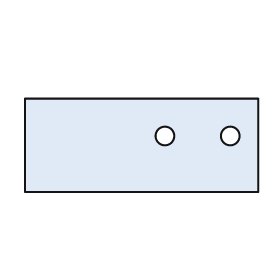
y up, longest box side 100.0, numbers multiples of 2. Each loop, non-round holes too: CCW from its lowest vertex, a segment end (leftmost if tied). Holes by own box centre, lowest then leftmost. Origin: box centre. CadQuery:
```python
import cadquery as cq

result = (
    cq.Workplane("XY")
    .moveTo(-50.0, -20.0)
    .lineTo(50.0, -20.0)
    .lineTo(50.0, 20.0)
    .lineTo(-50.0, 20.0)
    .close()
    .moveTo(10.0, 4.0)
    .circle(4.0)
    .moveTo(38.0, 4.0)
    .circle(4.0)
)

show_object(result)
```